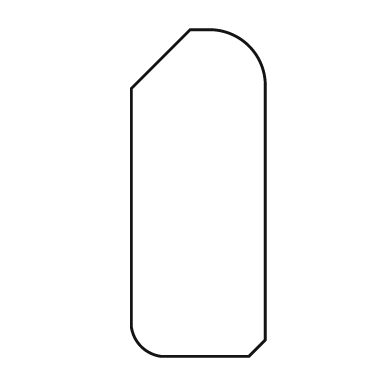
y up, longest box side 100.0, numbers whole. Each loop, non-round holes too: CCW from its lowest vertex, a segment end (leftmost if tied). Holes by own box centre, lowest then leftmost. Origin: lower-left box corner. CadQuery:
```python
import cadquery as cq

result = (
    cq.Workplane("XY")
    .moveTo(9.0, 0.0)
    .lineTo(36.0, 0.0)
    .lineTo(41.0, 5.0)
    .lineTo(41.0, 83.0)
    .threePointArc((36.0, 95.0), (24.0, 100.0))
    .lineTo(18.0, 100.0)
    .lineTo(0.0, 82.0)
    .lineTo(0.0, 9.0)
    .threePointArc((3.0, 3.0), (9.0, 0.0))
    .close()
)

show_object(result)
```